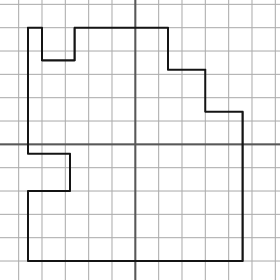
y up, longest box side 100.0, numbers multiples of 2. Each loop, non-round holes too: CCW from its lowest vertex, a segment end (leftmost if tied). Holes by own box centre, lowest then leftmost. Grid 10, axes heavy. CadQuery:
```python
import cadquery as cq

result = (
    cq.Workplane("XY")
    .moveTo(-46.0, -50.0)
    .lineTo(46.0, -50.0)
    .lineTo(46.0, 14.0)
    .lineTo(30.0, 14.0)
    .lineTo(30.0, 32.0)
    .lineTo(14.0, 32.0)
    .lineTo(14.0, 50.0)
    .lineTo(-26.0, 50.0)
    .lineTo(-26.0, 36.0)
    .lineTo(-40.0, 36.0)
    .lineTo(-40.0, 50.0)
    .lineTo(-46.0, 50.0)
    .lineTo(-46.0, -4.0)
    .lineTo(-28.0, -4.0)
    .lineTo(-28.0, -20.0)
    .lineTo(-46.0, -20.0)
    .close()
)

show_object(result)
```